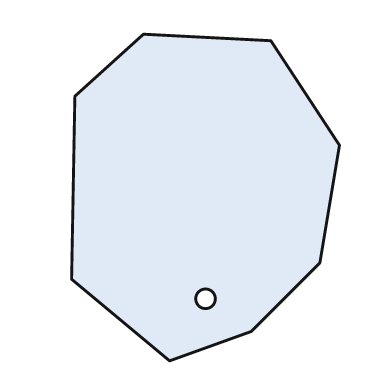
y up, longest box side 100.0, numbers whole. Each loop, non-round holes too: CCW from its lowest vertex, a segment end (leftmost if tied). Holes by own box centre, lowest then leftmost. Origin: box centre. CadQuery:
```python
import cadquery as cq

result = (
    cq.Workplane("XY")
    .moveTo(-11.0, -50.0)
    .lineTo(14.0, -41.0)
    .lineTo(35.0, -20.0)
    .lineTo(41.0, 16.0)
    .lineTo(20.0, 48.0)
    .lineTo(-19.0, 50.0)
    .lineTo(-40.0, 31.0)
    .lineTo(-41.0, -25.0)
    .close()
    .moveTo(0.0, -31.0)
    .circle(3.0)
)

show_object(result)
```